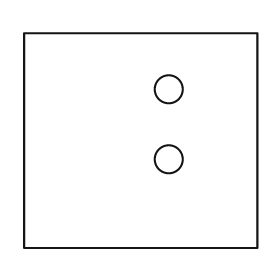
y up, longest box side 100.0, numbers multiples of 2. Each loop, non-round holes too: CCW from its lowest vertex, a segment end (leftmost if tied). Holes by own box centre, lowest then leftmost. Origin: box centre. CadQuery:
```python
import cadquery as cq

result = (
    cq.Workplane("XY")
    .moveTo(-50.0, -46.0)
    .lineTo(50.0, -46.0)
    .lineTo(50.0, 46.0)
    .lineTo(-50.0, 46.0)
    .close()
    .moveTo(12.0, -8.0)
    .circle(6.0)
    .moveTo(12.0, 22.0)
    .circle(6.0)
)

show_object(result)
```